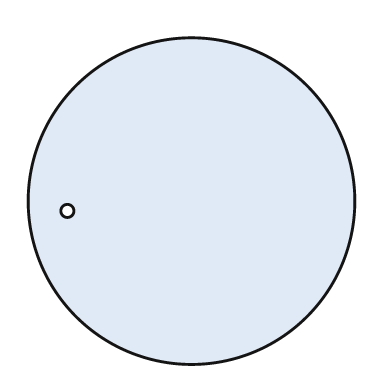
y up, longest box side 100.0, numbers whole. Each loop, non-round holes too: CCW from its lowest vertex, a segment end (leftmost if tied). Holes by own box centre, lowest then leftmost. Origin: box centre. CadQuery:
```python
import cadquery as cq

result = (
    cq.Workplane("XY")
    .moveTo(0.0, 0.0)
    .circle(50.0)
    .moveTo(-38.0, -3.0)
    .circle(2.0)
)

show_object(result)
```